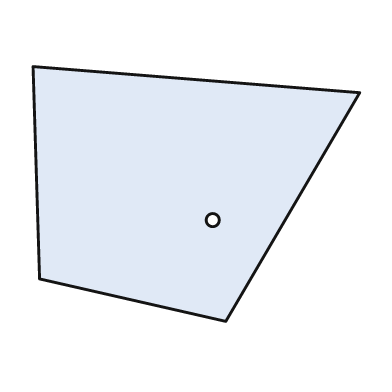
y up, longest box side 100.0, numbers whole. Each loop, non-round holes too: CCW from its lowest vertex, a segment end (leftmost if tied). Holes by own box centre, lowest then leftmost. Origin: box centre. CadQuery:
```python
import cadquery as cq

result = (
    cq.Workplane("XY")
    .moveTo(9.0, -39.0)
    .lineTo(50.0, 31.0)
    .lineTo(-50.0, 39.0)
    .lineTo(-48.0, -26.0)
    .close()
    .moveTo(5.0, -8.0)
    .circle(2.0)
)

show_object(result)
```